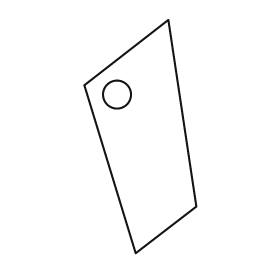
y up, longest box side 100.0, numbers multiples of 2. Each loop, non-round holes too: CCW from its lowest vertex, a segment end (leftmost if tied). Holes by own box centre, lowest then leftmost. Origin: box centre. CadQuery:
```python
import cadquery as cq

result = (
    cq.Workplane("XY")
    .moveTo(-2.0, -50.0)
    .lineTo(24.0, -30.0)
    .lineTo(12.0, 50.0)
    .lineTo(-24.0, 22.0)
    .close()
    .moveTo(-10.0, 18.0)
    .circle(6.0)
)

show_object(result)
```